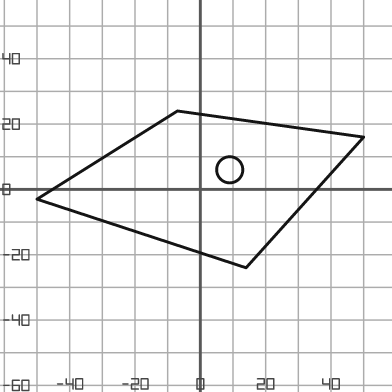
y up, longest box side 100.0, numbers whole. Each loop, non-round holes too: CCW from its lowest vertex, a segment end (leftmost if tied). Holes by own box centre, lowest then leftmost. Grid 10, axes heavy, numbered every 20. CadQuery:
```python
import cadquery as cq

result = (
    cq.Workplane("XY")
    .moveTo(14.0, -24.0)
    .lineTo(50.0, 16.0)
    .lineTo(-7.0, 24.0)
    .lineTo(-50.0, -3.0)
    .close()
    .moveTo(9.0, 6.0)
    .circle(4.0)
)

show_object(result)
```